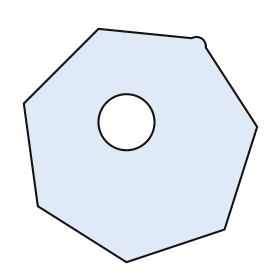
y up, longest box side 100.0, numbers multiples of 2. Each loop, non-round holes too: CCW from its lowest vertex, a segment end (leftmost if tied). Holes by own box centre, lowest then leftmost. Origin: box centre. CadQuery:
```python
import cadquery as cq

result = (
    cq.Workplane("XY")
    .moveTo(-6.0, -50.0)
    .lineTo(36.0, -36.0)
    .lineTo(50.0, 8.0)
    .lineTo(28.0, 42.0)
    .threePointArc((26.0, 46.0), (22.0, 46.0))
    .lineTo(-18.0, 50.0)
    .lineTo(-50.0, 18.0)
    .lineTo(-44.0, -26.0)
    .close()
    .moveTo(-6.0, 10.0)
    .circle(12.0)
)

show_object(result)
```